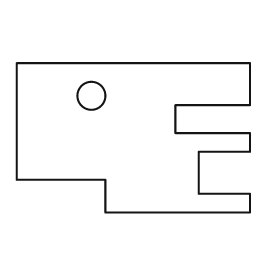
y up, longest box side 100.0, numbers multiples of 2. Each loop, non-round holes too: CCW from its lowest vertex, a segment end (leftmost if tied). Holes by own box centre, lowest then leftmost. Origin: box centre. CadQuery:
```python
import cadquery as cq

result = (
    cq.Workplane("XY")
    .moveTo(-12.0, -32.0)
    .lineTo(50.0, -32.0)
    .lineTo(50.0, -24.0)
    .lineTo(28.0, -24.0)
    .lineTo(28.0, -6.0)
    .lineTo(50.0, -6.0)
    .lineTo(50.0, 2.0)
    .lineTo(18.0, 2.0)
    .lineTo(18.0, 14.0)
    .lineTo(50.0, 14.0)
    .lineTo(50.0, 32.0)
    .lineTo(-50.0, 32.0)
    .lineTo(-50.0, -18.0)
    .lineTo(-12.0, -18.0)
    .close()
    .moveTo(-18.0, 18.0)
    .circle(6.0)
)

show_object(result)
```